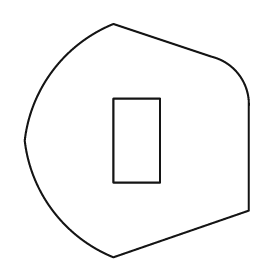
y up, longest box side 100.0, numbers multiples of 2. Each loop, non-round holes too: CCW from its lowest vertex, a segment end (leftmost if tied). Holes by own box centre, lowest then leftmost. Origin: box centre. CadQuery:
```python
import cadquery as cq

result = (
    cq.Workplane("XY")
    .moveTo(-10.0, -50.0)
    .lineTo(48.0, -30.0)
    .lineTo(48.0, 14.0)
    .threePointArc((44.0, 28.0), (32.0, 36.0))
    .lineTo(-10.0, 50.0)
    .threePointArc((-36.0, 30.0), (-48.0, 0.0))
    .threePointArc((-36.0, -30.0), (-10.0, -50.0))
    .close()
    .moveTo(-10.0, -18.0)
    .lineTo(10.0, -18.0)
    .lineTo(10.0, 18.0)
    .lineTo(-10.0, 18.0)
    .close()
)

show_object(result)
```